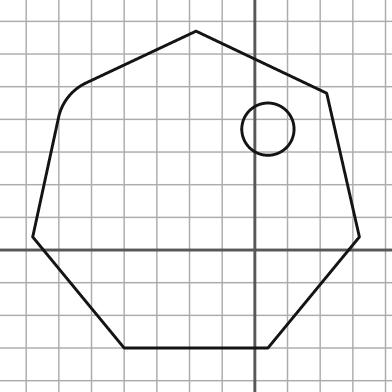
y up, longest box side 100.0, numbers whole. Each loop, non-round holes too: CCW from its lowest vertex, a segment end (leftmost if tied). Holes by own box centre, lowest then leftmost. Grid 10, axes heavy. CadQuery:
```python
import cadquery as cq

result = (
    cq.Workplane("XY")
    .moveTo(-40.0, -30.0)
    .lineTo(4.0, -30.0)
    .lineTo(32.0, 4.0)
    .lineTo(22.0, 48.0)
    .lineTo(-18.0, 67.0)
    .lineTo(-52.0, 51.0)
    .threePointArc((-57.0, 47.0), (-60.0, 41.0))
    .lineTo(-68.0, 4.0)
    .close()
    .moveTo(4.0, 37.0)
    .circle(8.0)
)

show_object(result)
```